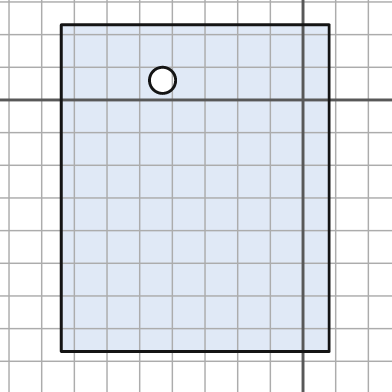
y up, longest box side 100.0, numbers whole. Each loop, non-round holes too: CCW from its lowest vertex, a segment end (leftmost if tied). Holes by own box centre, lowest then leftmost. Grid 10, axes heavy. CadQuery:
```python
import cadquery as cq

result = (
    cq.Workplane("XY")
    .moveTo(-74.0, -77.0)
    .lineTo(8.0, -77.0)
    .lineTo(8.0, 23.0)
    .lineTo(-74.0, 23.0)
    .close()
    .moveTo(-43.0, 6.0)
    .circle(4.0)
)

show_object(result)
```